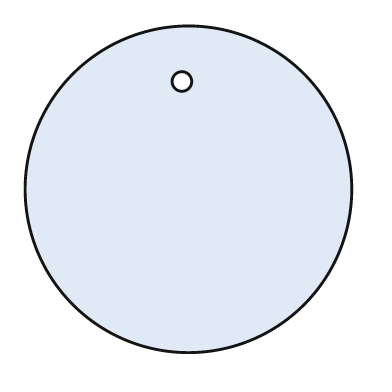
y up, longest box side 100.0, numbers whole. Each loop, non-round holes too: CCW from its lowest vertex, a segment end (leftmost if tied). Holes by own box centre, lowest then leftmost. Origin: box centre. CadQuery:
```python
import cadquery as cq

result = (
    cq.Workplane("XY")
    .moveTo(0.0, 0.0)
    .circle(50.0)
    .moveTo(-2.0, 33.0)
    .circle(3.0)
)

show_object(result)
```